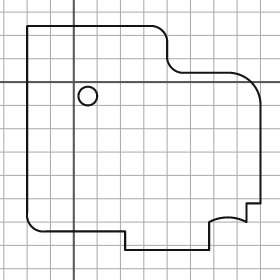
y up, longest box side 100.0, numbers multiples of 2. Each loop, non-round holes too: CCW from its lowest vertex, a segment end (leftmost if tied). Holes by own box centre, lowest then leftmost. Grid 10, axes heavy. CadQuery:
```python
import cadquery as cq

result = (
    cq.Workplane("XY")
    .moveTo(22.0, -72.0)
    .lineTo(58.0, -72.0)
    .lineTo(58.0, -60.0)
    .threePointArc((66.0, -58.0), (74.0, -60.0))
    .lineTo(74.0, -52.0)
    .lineTo(80.0, -52.0)
    .lineTo(80.0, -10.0)
    .threePointArc((76.0, 0.0), (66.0, 4.0))
    .lineTo(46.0, 4.0)
    .threePointArc((42.0, 6.0), (40.0, 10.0))
    .lineTo(40.0, 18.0)
    .threePointArc((38.0, 22.0), (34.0, 24.0))
    .lineTo(-20.0, 24.0)
    .lineTo(-20.0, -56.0)
    .threePointArc((-18.0, -62.0), (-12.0, -64.0))
    .lineTo(22.0, -64.0)
    .close()
    .moveTo(6.0, -6.0)
    .circle(4.0)
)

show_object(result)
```